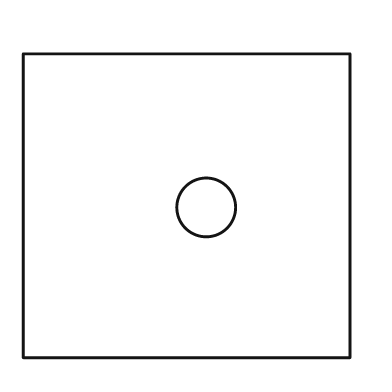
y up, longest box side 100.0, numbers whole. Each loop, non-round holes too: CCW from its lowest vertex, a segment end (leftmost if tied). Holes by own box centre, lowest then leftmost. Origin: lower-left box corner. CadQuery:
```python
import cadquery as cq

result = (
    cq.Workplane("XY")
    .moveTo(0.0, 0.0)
    .lineTo(100.0, 0.0)
    .lineTo(100.0, 93.0)
    .lineTo(0.0, 93.0)
    .close()
    .moveTo(56.0, 46.0)
    .circle(9.0)
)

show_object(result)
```